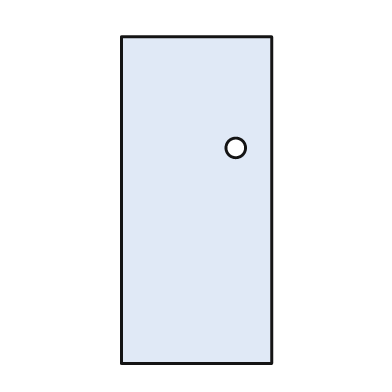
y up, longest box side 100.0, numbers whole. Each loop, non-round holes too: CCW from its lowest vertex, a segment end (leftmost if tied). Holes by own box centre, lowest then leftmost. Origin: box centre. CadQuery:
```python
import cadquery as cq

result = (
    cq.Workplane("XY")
    .moveTo(-23.0, -50.0)
    .lineTo(23.0, -50.0)
    .lineTo(23.0, 50.0)
    .lineTo(-23.0, 50.0)
    .close()
    .moveTo(12.0, 16.0)
    .circle(3.0)
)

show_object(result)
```